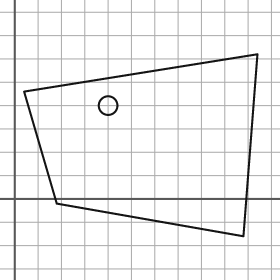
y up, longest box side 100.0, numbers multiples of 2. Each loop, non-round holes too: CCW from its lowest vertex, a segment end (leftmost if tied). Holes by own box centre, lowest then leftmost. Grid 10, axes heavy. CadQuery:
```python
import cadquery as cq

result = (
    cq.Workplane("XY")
    .moveTo(98.0, -16.0)
    .lineTo(104.0, 62.0)
    .lineTo(4.0, 46.0)
    .lineTo(18.0, -2.0)
    .close()
    .moveTo(40.0, 40.0)
    .circle(4.0)
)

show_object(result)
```